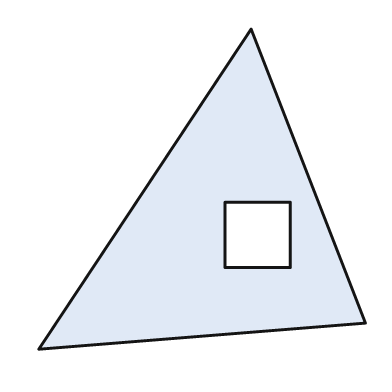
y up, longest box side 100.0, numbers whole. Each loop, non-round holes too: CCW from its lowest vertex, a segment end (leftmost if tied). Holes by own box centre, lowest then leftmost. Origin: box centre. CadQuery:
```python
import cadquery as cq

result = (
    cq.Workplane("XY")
    .moveTo(-50.0, -49.0)
    .lineTo(50.0, -41.0)
    .lineTo(15.0, 49.0)
    .close()
    .moveTo(7.0, -24.0)
    .lineTo(27.0, -24.0)
    .lineTo(27.0, -4.0)
    .lineTo(7.0, -4.0)
    .close()
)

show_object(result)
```